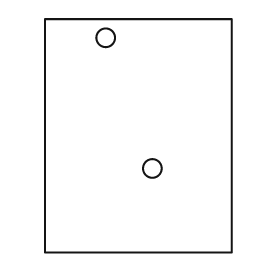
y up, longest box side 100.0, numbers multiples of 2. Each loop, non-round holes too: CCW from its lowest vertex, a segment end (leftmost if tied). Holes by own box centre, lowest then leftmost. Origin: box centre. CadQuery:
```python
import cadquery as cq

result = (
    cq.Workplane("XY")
    .moveTo(-40.0, -50.0)
    .lineTo(40.0, -50.0)
    .lineTo(40.0, 50.0)
    .lineTo(-40.0, 50.0)
    .close()
    .moveTo(6.0, -14.0)
    .circle(4.0)
    .moveTo(-14.0, 42.0)
    .circle(4.0)
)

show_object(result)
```